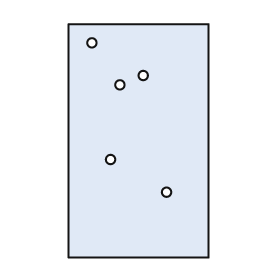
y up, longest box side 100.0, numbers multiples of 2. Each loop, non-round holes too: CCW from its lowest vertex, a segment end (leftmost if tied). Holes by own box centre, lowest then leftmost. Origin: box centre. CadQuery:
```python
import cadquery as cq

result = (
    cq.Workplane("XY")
    .moveTo(-30.0, -50.0)
    .lineTo(30.0, -50.0)
    .lineTo(30.0, 50.0)
    .lineTo(-30.0, 50.0)
    .close()
    .moveTo(12.0, -22.0)
    .circle(2.0)
    .moveTo(-12.0, -8.0)
    .circle(2.0)
    .moveTo(-8.0, 24.0)
    .circle(2.0)
    .moveTo(2.0, 28.0)
    .circle(2.0)
    .moveTo(-20.0, 42.0)
    .circle(2.0)
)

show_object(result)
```